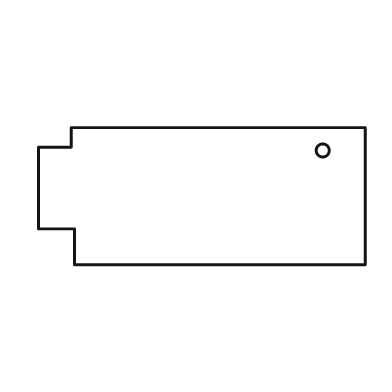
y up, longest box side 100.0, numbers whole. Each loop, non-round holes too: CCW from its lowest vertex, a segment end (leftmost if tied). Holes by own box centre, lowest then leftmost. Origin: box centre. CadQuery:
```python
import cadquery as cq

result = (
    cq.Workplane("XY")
    .moveTo(-39.0, -21.0)
    .lineTo(50.0, -21.0)
    .lineTo(50.0, 21.0)
    .lineTo(-40.0, 21.0)
    .lineTo(-40.0, 15.0)
    .lineTo(-50.0, 15.0)
    .lineTo(-50.0, -10.0)
    .lineTo(-39.0, -10.0)
    .close()
    .moveTo(37.0, 14.0)
    .circle(2.0)
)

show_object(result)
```